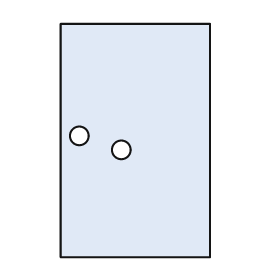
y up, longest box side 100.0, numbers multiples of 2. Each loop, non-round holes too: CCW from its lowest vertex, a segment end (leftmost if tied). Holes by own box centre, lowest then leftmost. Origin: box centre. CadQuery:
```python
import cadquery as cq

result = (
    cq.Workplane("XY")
    .moveTo(-32.0, -50.0)
    .lineTo(32.0, -50.0)
    .lineTo(32.0, 50.0)
    .lineTo(-32.0, 50.0)
    .close()
    .moveTo(-6.0, -4.0)
    .circle(4.0)
    .moveTo(-24.0, 2.0)
    .circle(4.0)
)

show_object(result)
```